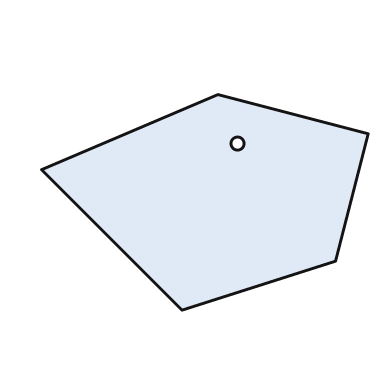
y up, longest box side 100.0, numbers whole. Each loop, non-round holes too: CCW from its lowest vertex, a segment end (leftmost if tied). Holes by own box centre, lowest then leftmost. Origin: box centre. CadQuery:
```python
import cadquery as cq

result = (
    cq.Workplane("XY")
    .moveTo(-7.0, -33.0)
    .lineTo(40.0, -18.0)
    .lineTo(50.0, 21.0)
    .lineTo(4.0, 33.0)
    .lineTo(-50.0, 10.0)
    .close()
    .moveTo(10.0, 18.0)
    .circle(2.0)
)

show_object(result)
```